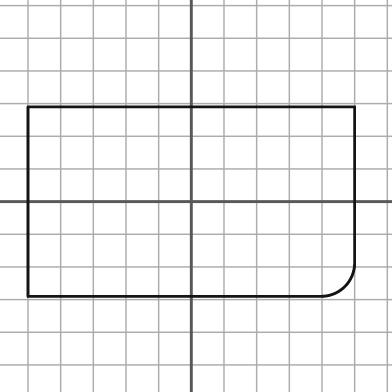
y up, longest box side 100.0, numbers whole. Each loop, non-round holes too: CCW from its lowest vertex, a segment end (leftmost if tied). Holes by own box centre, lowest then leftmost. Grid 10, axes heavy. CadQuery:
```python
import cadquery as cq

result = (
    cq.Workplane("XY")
    .moveTo(-50.0, -29.0)
    .lineTo(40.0, -29.0)
    .threePointArc((47.0, -26.0), (50.0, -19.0))
    .lineTo(50.0, 29.0)
    .lineTo(-50.0, 29.0)
    .close()
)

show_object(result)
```